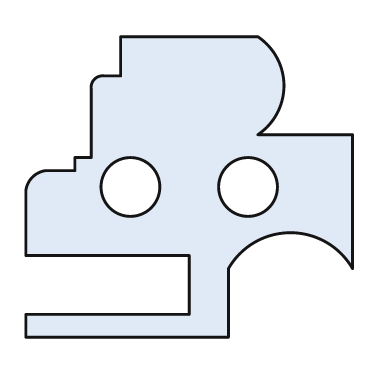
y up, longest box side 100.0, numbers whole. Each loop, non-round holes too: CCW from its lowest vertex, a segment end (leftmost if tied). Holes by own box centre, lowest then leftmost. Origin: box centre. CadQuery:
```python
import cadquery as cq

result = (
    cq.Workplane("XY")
    .moveTo(-50.0, -46.0)
    .lineTo(12.0, -46.0)
    .lineTo(12.0, -25.0)
    .threePointArc((31.0, -14.0), (50.0, -25.0))
    .lineTo(50.0, 16.0)
    .lineTo(21.0, 16.0)
    .threePointArc((29.0, 31.0), (21.0, 46.0))
    .lineTo(-21.0, 46.0)
    .lineTo(-21.0, 34.0)
    .lineTo(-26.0, 34.0)
    .threePointArc((-29.0, 33.0), (-30.0, 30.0))
    .lineTo(-30.0, 9.0)
    .lineTo(-35.0, 9.0)
    .lineTo(-35.0, 5.0)
    .lineTo(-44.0, 5.0)
    .threePointArc((-48.0, 3.0), (-50.0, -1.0))
    .lineTo(-50.0, -21.0)
    .lineTo(0.0, -21.0)
    .lineTo(0.0, -39.0)
    .lineTo(-50.0, -39.0)
    .close()
    .moveTo(-18.0, 0.0)
    .circle(9.0)
    .moveTo(18.0, 0.0)
    .circle(9.0)
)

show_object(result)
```